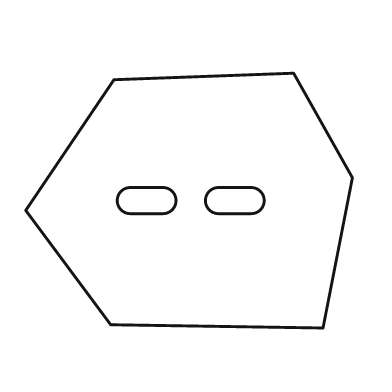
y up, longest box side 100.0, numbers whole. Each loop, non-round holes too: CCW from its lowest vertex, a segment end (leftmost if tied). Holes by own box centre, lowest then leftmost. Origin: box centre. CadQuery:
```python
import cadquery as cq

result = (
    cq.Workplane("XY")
    .moveTo(41.0, -39.0)
    .lineTo(50.0, 7.0)
    .lineTo(32.0, 39.0)
    .lineTo(-23.0, 37.0)
    .lineTo(-50.0, -3.0)
    .lineTo(-24.0, -38.0)
    .close()
    .moveTo(-18.0, -4.0)
    .lineTo(-8.0, -4.0)
    .threePointArc((-4.0, 0.0), (-8.0, 4.0))
    .lineTo(-18.0, 4.0)
    .threePointArc((-22.0, 0.0), (-18.0, -4.0))
    .close()
    .moveTo(9.0, -4.0)
    .lineTo(19.0, -4.0)
    .threePointArc((23.0, 0.0), (19.0, 4.0))
    .lineTo(9.0, 4.0)
    .threePointArc((5.0, 0.0), (9.0, -4.0))
    .close()
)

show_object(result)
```